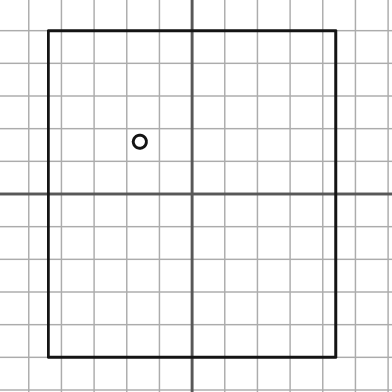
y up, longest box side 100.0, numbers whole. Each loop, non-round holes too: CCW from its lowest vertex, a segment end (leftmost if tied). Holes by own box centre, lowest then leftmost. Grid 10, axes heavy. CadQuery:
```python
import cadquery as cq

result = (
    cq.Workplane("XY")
    .moveTo(-44.0, -50.0)
    .lineTo(44.0, -50.0)
    .lineTo(44.0, 50.0)
    .lineTo(-44.0, 50.0)
    .close()
    .moveTo(-16.0, 16.0)
    .circle(2.0)
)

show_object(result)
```